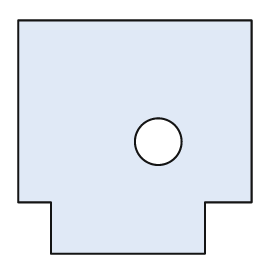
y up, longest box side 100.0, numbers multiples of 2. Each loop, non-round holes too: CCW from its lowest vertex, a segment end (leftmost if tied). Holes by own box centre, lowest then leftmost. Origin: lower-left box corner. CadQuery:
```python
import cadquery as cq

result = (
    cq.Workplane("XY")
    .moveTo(14.0, 0.0)
    .lineTo(80.0, 0.0)
    .lineTo(80.0, 22.0)
    .lineTo(100.0, 22.0)
    .lineTo(100.0, 100.0)
    .lineTo(0.0, 100.0)
    .lineTo(0.0, 22.0)
    .lineTo(14.0, 22.0)
    .close()
    .moveTo(60.0, 48.0)
    .circle(10.0)
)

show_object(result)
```